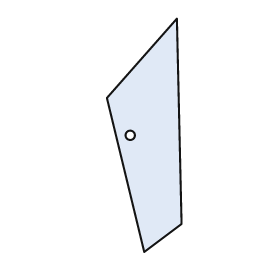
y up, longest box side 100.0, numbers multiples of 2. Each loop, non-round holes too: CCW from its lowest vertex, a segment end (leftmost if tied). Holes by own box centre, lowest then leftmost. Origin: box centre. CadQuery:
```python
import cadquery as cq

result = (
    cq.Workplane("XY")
    .moveTo(0.0, -50.0)
    .lineTo(16.0, -38.0)
    .lineTo(14.0, 50.0)
    .lineTo(-16.0, 16.0)
    .close()
    .moveTo(-6.0, 0.0)
    .circle(2.0)
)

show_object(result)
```